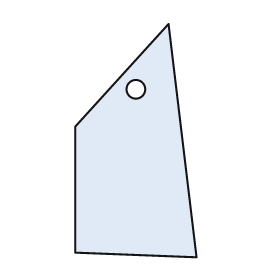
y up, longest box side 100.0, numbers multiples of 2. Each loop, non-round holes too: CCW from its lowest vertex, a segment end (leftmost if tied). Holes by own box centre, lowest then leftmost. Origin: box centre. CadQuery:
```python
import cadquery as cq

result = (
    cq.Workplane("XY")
    .moveTo(26.0, -50.0)
    .lineTo(14.0, 50.0)
    .lineTo(-26.0, 6.0)
    .lineTo(-26.0, -48.0)
    .close()
    .moveTo(0.0, 22.0)
    .circle(4.0)
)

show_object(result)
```